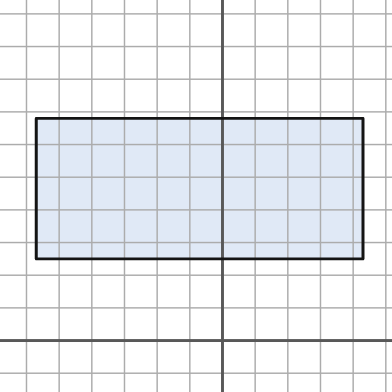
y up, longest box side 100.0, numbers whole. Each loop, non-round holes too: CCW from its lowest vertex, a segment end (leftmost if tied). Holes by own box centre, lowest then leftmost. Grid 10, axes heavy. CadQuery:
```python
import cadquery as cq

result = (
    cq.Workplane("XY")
    .moveTo(-57.0, 25.0)
    .lineTo(43.0, 25.0)
    .lineTo(43.0, 68.0)
    .lineTo(-57.0, 68.0)
    .close()
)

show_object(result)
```